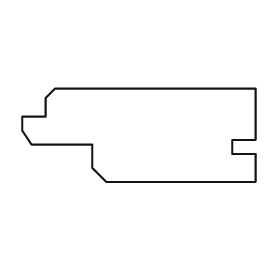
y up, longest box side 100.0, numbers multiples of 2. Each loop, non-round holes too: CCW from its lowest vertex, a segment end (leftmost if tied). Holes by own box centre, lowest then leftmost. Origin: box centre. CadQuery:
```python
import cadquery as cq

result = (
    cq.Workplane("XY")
    .moveTo(-14.0, -20.0)
    .lineTo(50.0, -20.0)
    .lineTo(50.0, -8.0)
    .lineTo(40.0, -8.0)
    .lineTo(40.0, -2.0)
    .lineTo(50.0, -2.0)
    .lineTo(50.0, 20.0)
    .lineTo(-36.0, 20.0)
    .lineTo(-40.0, 16.0)
    .lineTo(-40.0, 8.0)
    .lineTo(-50.0, 8.0)
    .lineTo(-50.0, 2.0)
    .lineTo(-46.0, -4.0)
    .lineTo(-20.0, -4.0)
    .lineTo(-20.0, -14.0)
    .close()
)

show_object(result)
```